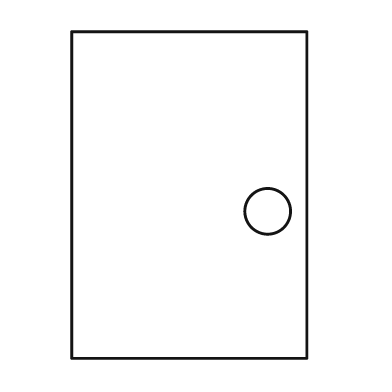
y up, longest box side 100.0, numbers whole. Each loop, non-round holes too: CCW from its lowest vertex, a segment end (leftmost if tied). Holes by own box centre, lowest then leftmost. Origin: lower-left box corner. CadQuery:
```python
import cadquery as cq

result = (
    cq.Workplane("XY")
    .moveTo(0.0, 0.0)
    .lineTo(72.0, 0.0)
    .lineTo(72.0, 100.0)
    .lineTo(0.0, 100.0)
    .close()
    .moveTo(60.0, 45.0)
    .circle(7.0)
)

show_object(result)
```